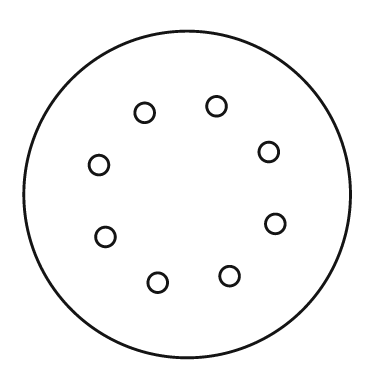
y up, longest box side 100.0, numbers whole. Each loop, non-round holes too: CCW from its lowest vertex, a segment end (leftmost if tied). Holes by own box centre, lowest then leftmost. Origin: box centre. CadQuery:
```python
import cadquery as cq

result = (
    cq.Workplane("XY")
    .moveTo(0.0, 0.0)
    .circle(50.0)
    .moveTo(-9.0, -27.0)
    .circle(3.0)
    .moveTo(13.0, -25.0)
    .circle(3.0)
    .moveTo(-25.0, -13.0)
    .circle(3.0)
    .moveTo(27.0, -9.0)
    .circle(3.0)
    .moveTo(-27.0, 9.0)
    .circle(3.0)
    .moveTo(25.0, 13.0)
    .circle(3.0)
    .moveTo(-13.0, 25.0)
    .circle(3.0)
    .moveTo(9.0, 27.0)
    .circle(3.0)
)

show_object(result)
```